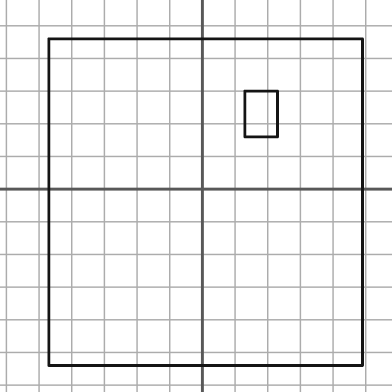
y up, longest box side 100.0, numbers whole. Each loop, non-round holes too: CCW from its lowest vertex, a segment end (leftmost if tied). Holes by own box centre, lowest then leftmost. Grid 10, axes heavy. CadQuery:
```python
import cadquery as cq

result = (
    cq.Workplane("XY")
    .moveTo(-47.0, -54.0)
    .lineTo(49.0, -54.0)
    .lineTo(49.0, 46.0)
    .lineTo(-47.0, 46.0)
    .close()
    .moveTo(13.0, 16.0)
    .lineTo(23.0, 16.0)
    .lineTo(23.0, 30.0)
    .lineTo(13.0, 30.0)
    .close()
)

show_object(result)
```